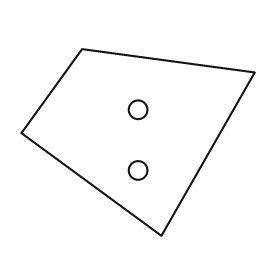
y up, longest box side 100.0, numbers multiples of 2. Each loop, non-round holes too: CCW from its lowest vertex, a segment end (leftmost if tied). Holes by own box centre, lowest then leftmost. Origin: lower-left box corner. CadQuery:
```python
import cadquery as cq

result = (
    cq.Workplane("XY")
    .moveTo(60.0, 0.0)
    .lineTo(100.0, 70.0)
    .lineTo(26.0, 80.0)
    .lineTo(0.0, 44.0)
    .close()
    .moveTo(50.0, 28.0)
    .circle(4.0)
    .moveTo(50.0, 54.0)
    .circle(4.0)
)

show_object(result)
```